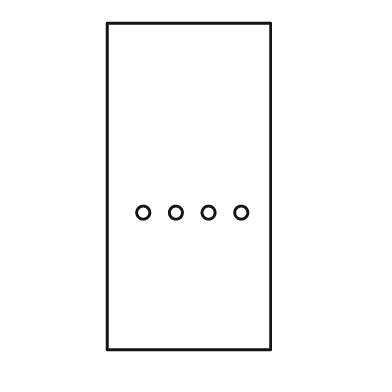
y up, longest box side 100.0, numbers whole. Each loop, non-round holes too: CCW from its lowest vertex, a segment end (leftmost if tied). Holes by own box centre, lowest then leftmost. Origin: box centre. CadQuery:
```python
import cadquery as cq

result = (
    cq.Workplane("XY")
    .moveTo(-25.0, -50.0)
    .lineTo(25.0, -50.0)
    .lineTo(25.0, 50.0)
    .lineTo(-25.0, 50.0)
    .close()
    .moveTo(-14.0, -8.0)
    .circle(2.0)
    .moveTo(-4.0, -8.0)
    .circle(2.0)
    .moveTo(6.0, -8.0)
    .circle(2.0)
    .moveTo(16.0, -8.0)
    .circle(2.0)
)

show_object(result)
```